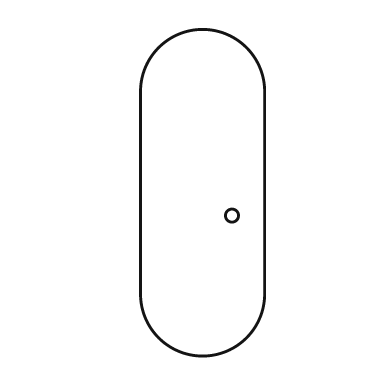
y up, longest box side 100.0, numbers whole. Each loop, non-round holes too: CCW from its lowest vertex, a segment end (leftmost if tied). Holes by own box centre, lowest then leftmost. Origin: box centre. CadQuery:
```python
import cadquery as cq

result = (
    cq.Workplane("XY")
    .moveTo(-19.0, -31.0)
    .threePointArc((0.0, -50.0), (19.0, -31.0))
    .lineTo(19.0, 31.0)
    .threePointArc((0.0, 50.0), (-19.0, 31.0))
    .close()
    .moveTo(9.0, -7.0)
    .circle(2.0)
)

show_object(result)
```